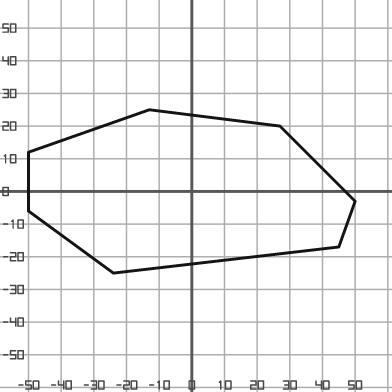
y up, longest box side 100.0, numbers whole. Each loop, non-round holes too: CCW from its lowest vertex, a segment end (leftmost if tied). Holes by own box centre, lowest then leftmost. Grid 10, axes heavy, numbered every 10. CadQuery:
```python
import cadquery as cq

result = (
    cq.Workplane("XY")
    .moveTo(-24.0, -25.0)
    .lineTo(45.0, -17.0)
    .lineTo(50.0, -3.0)
    .lineTo(27.0, 20.0)
    .lineTo(-13.0, 25.0)
    .lineTo(-50.0, 12.0)
    .lineTo(-50.0, -6.0)
    .close()
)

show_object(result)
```